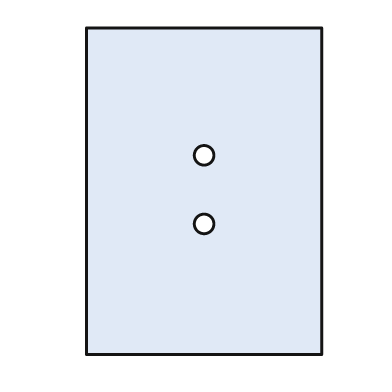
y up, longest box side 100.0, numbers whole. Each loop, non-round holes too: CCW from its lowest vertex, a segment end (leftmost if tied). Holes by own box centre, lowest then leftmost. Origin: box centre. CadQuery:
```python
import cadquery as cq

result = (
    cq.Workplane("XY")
    .moveTo(-36.0, -50.0)
    .lineTo(36.0, -50.0)
    .lineTo(36.0, 50.0)
    .lineTo(-36.0, 50.0)
    .close()
    .moveTo(0.0, -10.0)
    .circle(3.0)
    .moveTo(0.0, 11.0)
    .circle(3.0)
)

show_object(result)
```